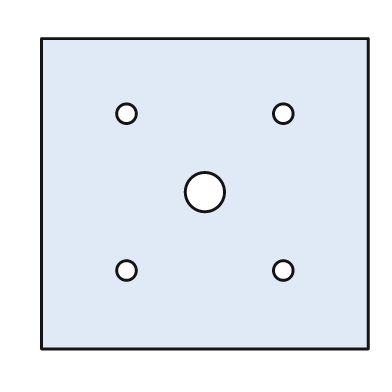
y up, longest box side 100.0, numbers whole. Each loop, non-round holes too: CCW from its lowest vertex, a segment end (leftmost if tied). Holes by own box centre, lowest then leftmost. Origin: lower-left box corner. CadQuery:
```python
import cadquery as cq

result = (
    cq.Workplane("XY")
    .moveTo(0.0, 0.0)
    .lineTo(100.0, 0.0)
    .lineTo(100.0, 95.0)
    .lineTo(0.0, 95.0)
    .close()
    .moveTo(26.0, 24.0)
    .circle(3.0)
    .moveTo(74.0, 24.0)
    .circle(3.0)
    .moveTo(50.0, 48.0)
    .circle(6.0)
    .moveTo(26.0, 72.0)
    .circle(3.0)
    .moveTo(74.0, 72.0)
    .circle(3.0)
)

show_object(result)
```